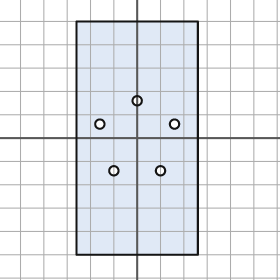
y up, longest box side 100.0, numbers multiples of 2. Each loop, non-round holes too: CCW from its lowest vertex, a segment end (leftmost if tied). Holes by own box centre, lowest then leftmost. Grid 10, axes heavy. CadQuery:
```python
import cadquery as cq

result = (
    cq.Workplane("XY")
    .moveTo(-26.0, -50.0)
    .lineTo(26.0, -50.0)
    .lineTo(26.0, 50.0)
    .lineTo(-26.0, 50.0)
    .close()
    .moveTo(-10.0, -14.0)
    .circle(2.0)
    .moveTo(10.0, -14.0)
    .circle(2.0)
    .moveTo(-16.0, 6.0)
    .circle(2.0)
    .moveTo(16.0, 6.0)
    .circle(2.0)
    .moveTo(0.0, 16.0)
    .circle(2.0)
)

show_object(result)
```